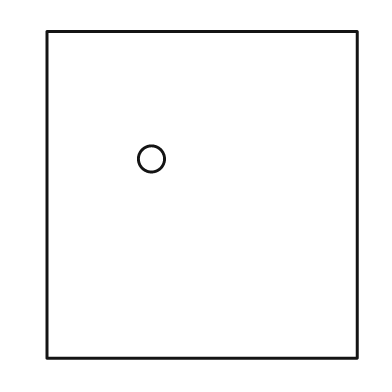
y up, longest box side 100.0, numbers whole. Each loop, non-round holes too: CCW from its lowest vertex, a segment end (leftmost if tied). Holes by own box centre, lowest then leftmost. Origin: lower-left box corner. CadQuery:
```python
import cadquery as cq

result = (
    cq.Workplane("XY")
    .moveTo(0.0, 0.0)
    .lineTo(95.0, 0.0)
    .lineTo(95.0, 100.0)
    .lineTo(0.0, 100.0)
    .close()
    .moveTo(32.0, 61.0)
    .circle(4.0)
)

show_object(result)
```